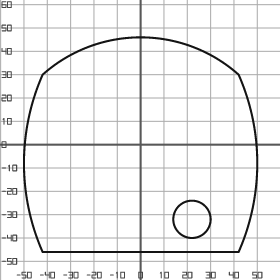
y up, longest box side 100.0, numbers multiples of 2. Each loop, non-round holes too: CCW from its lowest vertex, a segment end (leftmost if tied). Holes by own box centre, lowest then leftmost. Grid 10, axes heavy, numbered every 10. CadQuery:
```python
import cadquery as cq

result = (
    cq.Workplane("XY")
    .moveTo(-42.0, -46.0)
    .lineTo(42.0, -46.0)
    .threePointArc((50.0, -8.0), (42.0, 30.0))
    .threePointArc((0.0, 46.0), (-42.0, 30.0))
    .threePointArc((-50.0, -8.0), (-42.0, -46.0))
    .close()
    .moveTo(22.0, -32.0)
    .circle(8.0)
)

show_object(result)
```